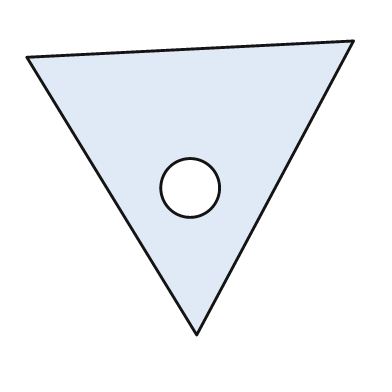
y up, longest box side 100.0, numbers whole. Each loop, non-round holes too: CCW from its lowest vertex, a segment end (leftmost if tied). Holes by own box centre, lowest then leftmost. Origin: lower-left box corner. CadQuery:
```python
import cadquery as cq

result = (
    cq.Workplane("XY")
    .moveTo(52.0, 0.0)
    .lineTo(100.0, 90.0)
    .lineTo(0.0, 85.0)
    .close()
    .moveTo(50.0, 45.0)
    .circle(9.0)
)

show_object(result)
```